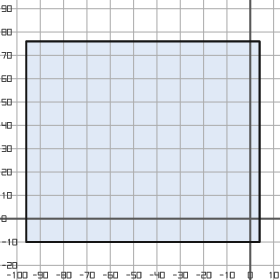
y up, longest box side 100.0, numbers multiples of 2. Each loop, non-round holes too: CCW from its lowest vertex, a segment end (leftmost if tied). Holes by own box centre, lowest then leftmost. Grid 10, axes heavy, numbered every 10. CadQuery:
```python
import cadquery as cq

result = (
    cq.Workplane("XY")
    .moveTo(-96.0, -10.0)
    .lineTo(4.0, -10.0)
    .lineTo(4.0, 76.0)
    .lineTo(-96.0, 76.0)
    .close()
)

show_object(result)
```